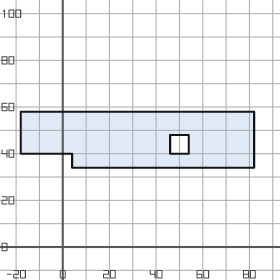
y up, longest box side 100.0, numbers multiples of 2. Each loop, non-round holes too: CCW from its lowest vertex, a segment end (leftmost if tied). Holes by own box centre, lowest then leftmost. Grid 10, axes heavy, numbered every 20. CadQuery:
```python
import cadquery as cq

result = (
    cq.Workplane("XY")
    .moveTo(4.0, 34.0)
    .lineTo(82.0, 34.0)
    .lineTo(82.0, 58.0)
    .lineTo(-18.0, 58.0)
    .lineTo(-18.0, 40.0)
    .lineTo(4.0, 40.0)
    .close()
    .moveTo(46.0, 40.0)
    .lineTo(54.0, 40.0)
    .lineTo(54.0, 48.0)
    .lineTo(46.0, 48.0)
    .close()
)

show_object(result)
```